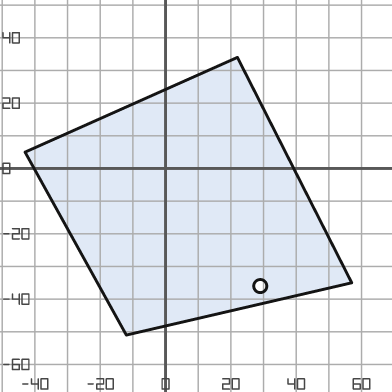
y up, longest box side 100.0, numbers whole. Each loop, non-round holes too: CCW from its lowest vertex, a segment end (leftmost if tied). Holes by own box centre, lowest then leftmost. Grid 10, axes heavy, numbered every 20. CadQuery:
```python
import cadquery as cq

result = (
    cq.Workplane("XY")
    .moveTo(-12.0, -51.0)
    .lineTo(57.0, -35.0)
    .lineTo(22.0, 34.0)
    .lineTo(-43.0, 5.0)
    .close()
    .moveTo(29.0, -36.0)
    .circle(2.0)
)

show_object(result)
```